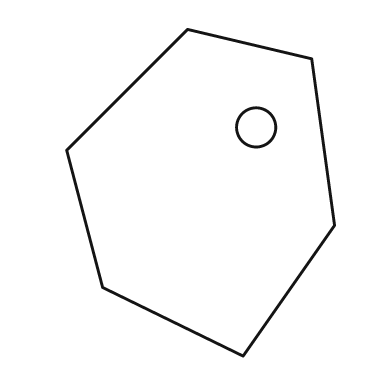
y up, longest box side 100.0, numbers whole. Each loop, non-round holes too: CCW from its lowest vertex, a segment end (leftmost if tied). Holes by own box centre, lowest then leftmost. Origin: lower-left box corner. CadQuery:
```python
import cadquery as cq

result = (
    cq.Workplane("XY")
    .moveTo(54.0, 0.0)
    .lineTo(82.0, 40.0)
    .lineTo(75.0, 91.0)
    .lineTo(37.0, 100.0)
    .lineTo(0.0, 63.0)
    .lineTo(11.0, 21.0)
    .close()
    .moveTo(58.0, 70.0)
    .circle(6.0)
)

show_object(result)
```